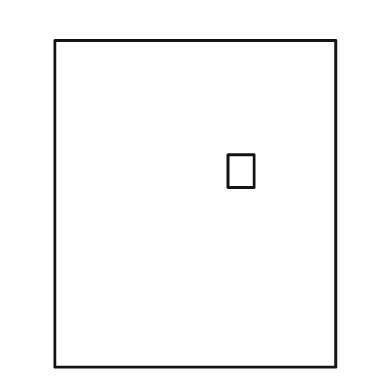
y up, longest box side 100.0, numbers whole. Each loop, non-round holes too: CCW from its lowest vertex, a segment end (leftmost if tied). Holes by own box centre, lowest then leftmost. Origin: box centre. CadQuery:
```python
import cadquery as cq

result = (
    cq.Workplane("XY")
    .moveTo(-43.0, -50.0)
    .lineTo(43.0, -50.0)
    .lineTo(43.0, 50.0)
    .lineTo(-43.0, 50.0)
    .close()
    .moveTo(10.0, 5.0)
    .lineTo(18.0, 5.0)
    .lineTo(18.0, 15.0)
    .lineTo(10.0, 15.0)
    .close()
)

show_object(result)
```